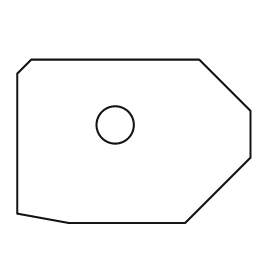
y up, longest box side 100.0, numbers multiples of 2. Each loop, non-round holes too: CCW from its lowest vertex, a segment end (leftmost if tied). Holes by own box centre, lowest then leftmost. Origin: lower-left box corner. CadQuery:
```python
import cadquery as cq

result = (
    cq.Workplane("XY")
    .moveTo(22.0, 0.0)
    .lineTo(72.0, 0.0)
    .lineTo(100.0, 28.0)
    .lineTo(100.0, 48.0)
    .lineTo(78.0, 70.0)
    .lineTo(6.0, 70.0)
    .lineTo(0.0, 64.0)
    .lineTo(0.0, 4.0)
    .close()
    .moveTo(42.0, 42.0)
    .circle(8.0)
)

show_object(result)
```